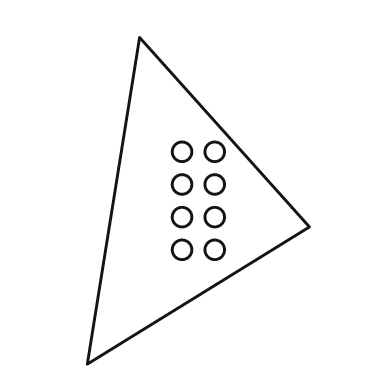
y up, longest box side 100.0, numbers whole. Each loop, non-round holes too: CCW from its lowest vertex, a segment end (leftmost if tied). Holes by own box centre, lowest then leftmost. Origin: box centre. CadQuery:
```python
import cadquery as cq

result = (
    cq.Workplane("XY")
    .moveTo(-34.0, -50.0)
    .lineTo(34.0, -8.0)
    .lineTo(-18.0, 50.0)
    .close()
    .moveTo(-5.0, -15.0)
    .circle(3.0)
    .moveTo(5.0, -15.0)
    .circle(3.0)
    .moveTo(-5.0, -5.0)
    .circle(3.0)
    .moveTo(5.0, -5.0)
    .circle(3.0)
    .moveTo(-5.0, 5.0)
    .circle(3.0)
    .moveTo(5.0, 5.0)
    .circle(3.0)
    .moveTo(-5.0, 15.0)
    .circle(3.0)
    .moveTo(5.0, 15.0)
    .circle(3.0)
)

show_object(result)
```